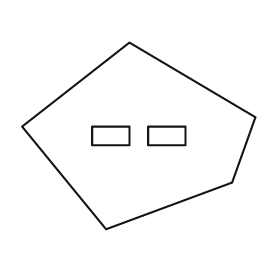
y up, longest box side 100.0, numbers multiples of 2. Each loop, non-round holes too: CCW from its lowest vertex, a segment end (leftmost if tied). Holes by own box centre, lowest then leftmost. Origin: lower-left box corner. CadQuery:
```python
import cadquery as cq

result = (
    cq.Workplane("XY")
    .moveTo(36.0, 0.0)
    .lineTo(90.0, 20.0)
    .lineTo(100.0, 48.0)
    .lineTo(46.0, 80.0)
    .lineTo(0.0, 44.0)
    .close()
    .moveTo(30.0, 36.0)
    .lineTo(46.0, 36.0)
    .lineTo(46.0, 44.0)
    .lineTo(30.0, 44.0)
    .close()
    .moveTo(54.0, 36.0)
    .lineTo(70.0, 36.0)
    .lineTo(70.0, 44.0)
    .lineTo(54.0, 44.0)
    .close()
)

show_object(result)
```